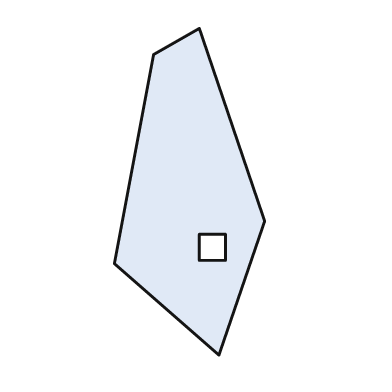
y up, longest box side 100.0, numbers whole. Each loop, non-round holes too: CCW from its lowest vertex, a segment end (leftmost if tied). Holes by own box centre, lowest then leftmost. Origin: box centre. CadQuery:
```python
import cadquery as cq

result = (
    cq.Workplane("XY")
    .moveTo(9.0, -50.0)
    .lineTo(23.0, -9.0)
    .lineTo(3.0, 50.0)
    .lineTo(-11.0, 42.0)
    .lineTo(-23.0, -22.0)
    .close()
    .moveTo(3.0, -21.0)
    .lineTo(11.0, -21.0)
    .lineTo(11.0, -13.0)
    .lineTo(3.0, -13.0)
    .close()
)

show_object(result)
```